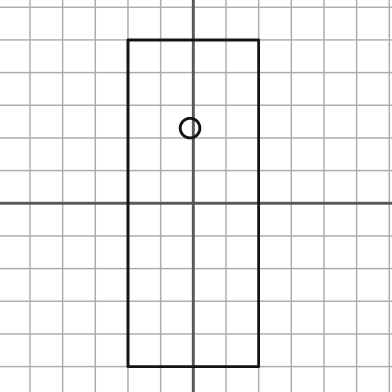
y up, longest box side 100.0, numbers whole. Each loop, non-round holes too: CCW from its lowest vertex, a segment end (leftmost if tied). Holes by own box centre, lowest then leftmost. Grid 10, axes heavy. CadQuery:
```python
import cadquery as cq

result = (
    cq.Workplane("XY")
    .moveTo(-20.0, -50.0)
    .lineTo(20.0, -50.0)
    .lineTo(20.0, 50.0)
    .lineTo(-20.0, 50.0)
    .close()
    .moveTo(-1.0, 23.0)
    .circle(3.0)
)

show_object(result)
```